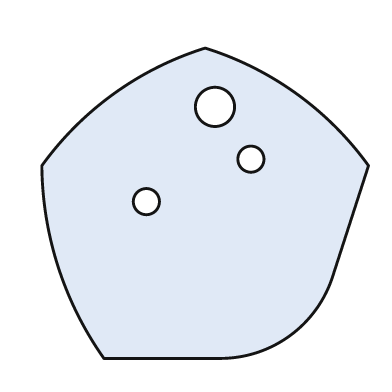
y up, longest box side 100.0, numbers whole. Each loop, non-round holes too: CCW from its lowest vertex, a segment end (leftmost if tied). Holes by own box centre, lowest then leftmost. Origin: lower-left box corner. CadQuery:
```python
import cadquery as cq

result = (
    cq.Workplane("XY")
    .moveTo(19.0, 0.0)
    .lineTo(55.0, 0.0)
    .threePointArc((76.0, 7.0), (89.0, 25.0))
    .lineTo(100.0, 59.0)
    .threePointArc((78.0, 81.0), (50.0, 95.0))
    .threePointArc((22.0, 81.0), (0.0, 59.0))
    .threePointArc((5.0, 28.0), (19.0, 0.0))
    .close()
    .moveTo(32.0, 48.0)
    .circle(4.0)
    .moveTo(64.0, 61.0)
    .circle(4.0)
    .moveTo(53.0, 77.0)
    .circle(6.0)
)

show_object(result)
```